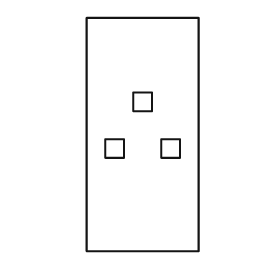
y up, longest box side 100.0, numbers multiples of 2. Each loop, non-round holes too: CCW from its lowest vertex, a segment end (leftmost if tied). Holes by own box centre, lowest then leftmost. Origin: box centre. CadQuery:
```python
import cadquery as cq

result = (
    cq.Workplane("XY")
    .moveTo(-24.0, -50.0)
    .lineTo(24.0, -50.0)
    .lineTo(24.0, 50.0)
    .lineTo(-24.0, 50.0)
    .close()
    .moveTo(-16.0, -10.0)
    .lineTo(-8.0, -10.0)
    .lineTo(-8.0, -2.0)
    .lineTo(-16.0, -2.0)
    .close()
    .moveTo(8.0, -10.0)
    .lineTo(16.0, -10.0)
    .lineTo(16.0, -2.0)
    .lineTo(8.0, -2.0)
    .close()
    .moveTo(-4.0, 10.0)
    .lineTo(4.0, 10.0)
    .lineTo(4.0, 18.0)
    .lineTo(-4.0, 18.0)
    .close()
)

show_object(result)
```